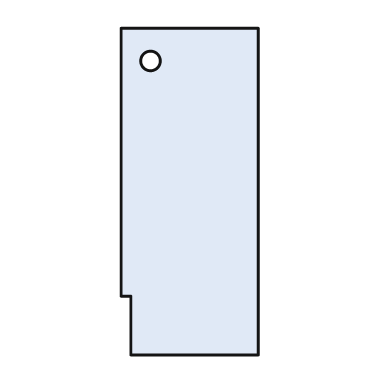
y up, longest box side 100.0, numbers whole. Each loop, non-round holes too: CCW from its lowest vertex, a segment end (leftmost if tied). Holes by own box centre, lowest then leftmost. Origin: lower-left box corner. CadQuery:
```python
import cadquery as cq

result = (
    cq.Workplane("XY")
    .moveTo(3.0, 0.0)
    .lineTo(42.0, 0.0)
    .lineTo(42.0, 100.0)
    .lineTo(0.0, 100.0)
    .lineTo(0.0, 18.0)
    .lineTo(3.0, 18.0)
    .close()
    .moveTo(9.0, 90.0)
    .circle(3.0)
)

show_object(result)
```